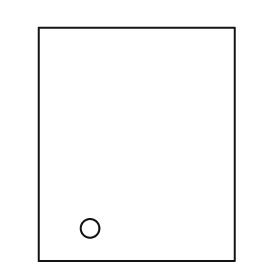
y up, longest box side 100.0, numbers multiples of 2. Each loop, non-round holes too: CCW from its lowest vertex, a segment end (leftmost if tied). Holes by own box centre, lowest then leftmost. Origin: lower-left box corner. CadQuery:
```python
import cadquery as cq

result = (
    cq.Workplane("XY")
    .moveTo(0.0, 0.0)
    .lineTo(84.0, 0.0)
    .lineTo(84.0, 100.0)
    .lineTo(0.0, 100.0)
    .close()
    .moveTo(22.0, 14.0)
    .circle(4.0)
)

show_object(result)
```